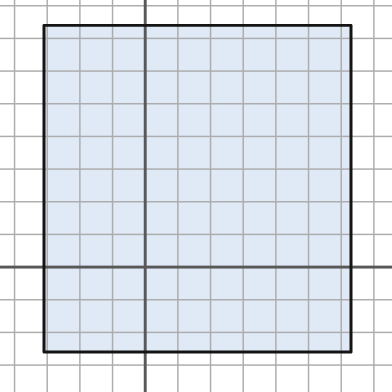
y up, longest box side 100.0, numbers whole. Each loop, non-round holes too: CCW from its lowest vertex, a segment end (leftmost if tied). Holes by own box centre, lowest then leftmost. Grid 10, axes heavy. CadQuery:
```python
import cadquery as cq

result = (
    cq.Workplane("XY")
    .moveTo(-31.0, -26.0)
    .lineTo(63.0, -26.0)
    .lineTo(63.0, 74.0)
    .lineTo(-31.0, 74.0)
    .close()
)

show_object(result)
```